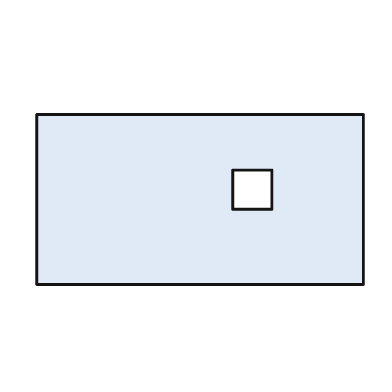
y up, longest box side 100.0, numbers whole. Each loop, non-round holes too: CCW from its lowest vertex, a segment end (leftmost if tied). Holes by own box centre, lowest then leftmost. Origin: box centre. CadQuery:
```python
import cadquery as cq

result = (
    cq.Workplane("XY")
    .moveTo(-50.0, -26.0)
    .lineTo(50.0, -26.0)
    .lineTo(50.0, 26.0)
    .lineTo(-50.0, 26.0)
    .close()
    .moveTo(10.0, -3.0)
    .lineTo(22.0, -3.0)
    .lineTo(22.0, 9.0)
    .lineTo(10.0, 9.0)
    .close()
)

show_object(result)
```